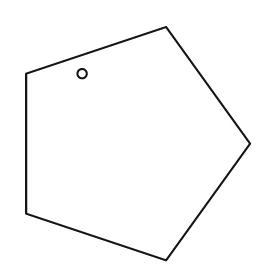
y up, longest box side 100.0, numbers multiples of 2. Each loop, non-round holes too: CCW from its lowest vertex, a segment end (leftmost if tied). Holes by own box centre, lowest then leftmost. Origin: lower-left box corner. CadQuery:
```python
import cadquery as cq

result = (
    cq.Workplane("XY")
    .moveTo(60.0, 0.0)
    .lineTo(96.0, 50.0)
    .lineTo(60.0, 100.0)
    .lineTo(0.0, 80.0)
    .lineTo(0.0, 20.0)
    .close()
    .moveTo(24.0, 80.0)
    .circle(2.0)
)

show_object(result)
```